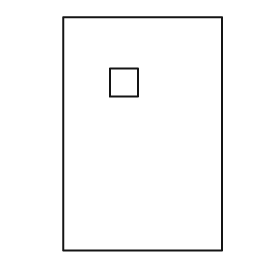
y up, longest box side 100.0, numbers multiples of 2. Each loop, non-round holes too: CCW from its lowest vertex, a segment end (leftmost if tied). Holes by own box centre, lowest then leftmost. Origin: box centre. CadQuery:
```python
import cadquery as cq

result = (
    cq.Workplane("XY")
    .moveTo(-34.0, -50.0)
    .lineTo(34.0, -50.0)
    .lineTo(34.0, 50.0)
    .lineTo(-34.0, 50.0)
    .close()
    .moveTo(-14.0, 16.0)
    .lineTo(-2.0, 16.0)
    .lineTo(-2.0, 28.0)
    .lineTo(-14.0, 28.0)
    .close()
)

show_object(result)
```